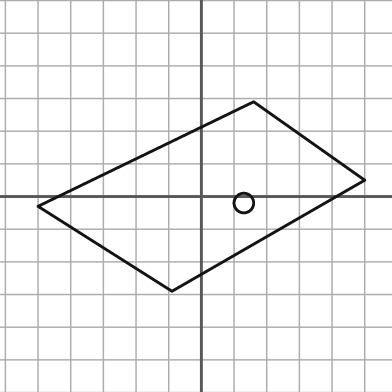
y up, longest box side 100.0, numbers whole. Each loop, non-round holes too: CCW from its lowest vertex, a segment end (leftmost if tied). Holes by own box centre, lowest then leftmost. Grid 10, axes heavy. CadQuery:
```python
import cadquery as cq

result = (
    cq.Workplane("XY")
    .moveTo(-9.0, -29.0)
    .lineTo(50.0, 5.0)
    .lineTo(16.0, 29.0)
    .lineTo(-50.0, -3.0)
    .close()
    .moveTo(13.0, -2.0)
    .circle(3.0)
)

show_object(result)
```